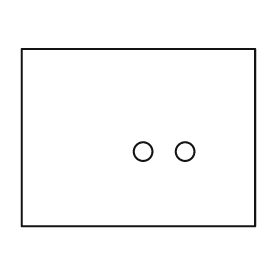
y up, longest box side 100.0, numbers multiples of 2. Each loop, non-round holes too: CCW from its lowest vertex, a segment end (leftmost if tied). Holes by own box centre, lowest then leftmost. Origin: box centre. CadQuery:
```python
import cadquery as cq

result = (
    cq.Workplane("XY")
    .moveTo(-50.0, -38.0)
    .lineTo(50.0, -38.0)
    .lineTo(50.0, 38.0)
    .lineTo(-50.0, 38.0)
    .close()
    .moveTo(2.0, -6.0)
    .circle(4.0)
    .moveTo(20.0, -6.0)
    .circle(4.0)
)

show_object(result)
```